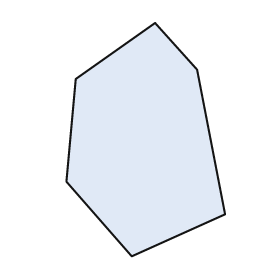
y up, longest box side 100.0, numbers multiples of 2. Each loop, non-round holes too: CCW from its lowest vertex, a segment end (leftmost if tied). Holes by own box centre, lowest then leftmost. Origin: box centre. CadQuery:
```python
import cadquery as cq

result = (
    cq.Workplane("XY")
    .moveTo(-6.0, -50.0)
    .lineTo(34.0, -32.0)
    .lineTo(22.0, 30.0)
    .lineTo(4.0, 50.0)
    .lineTo(-30.0, 26.0)
    .lineTo(-34.0, -18.0)
    .close()
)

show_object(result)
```